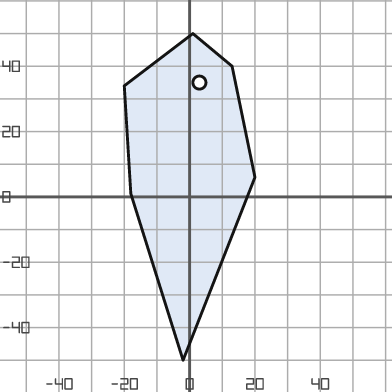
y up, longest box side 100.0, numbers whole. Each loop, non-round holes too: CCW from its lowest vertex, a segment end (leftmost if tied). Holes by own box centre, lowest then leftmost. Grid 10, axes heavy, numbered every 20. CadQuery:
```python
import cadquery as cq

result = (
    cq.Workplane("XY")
    .moveTo(-2.0, -50.0)
    .lineTo(20.0, 6.0)
    .lineTo(13.0, 40.0)
    .lineTo(1.0, 50.0)
    .lineTo(-20.0, 34.0)
    .lineTo(-18.0, 1.0)
    .close()
    .moveTo(3.0, 35.0)
    .circle(2.0)
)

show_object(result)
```